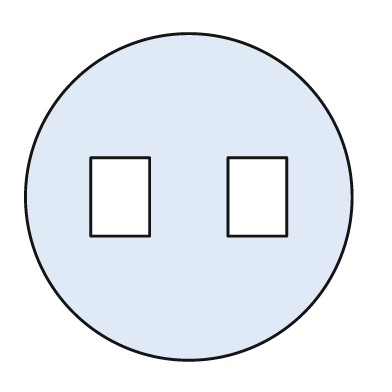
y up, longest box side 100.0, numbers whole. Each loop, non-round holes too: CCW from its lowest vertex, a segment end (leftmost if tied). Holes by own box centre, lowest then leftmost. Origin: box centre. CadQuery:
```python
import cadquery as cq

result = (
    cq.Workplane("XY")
    .moveTo(0.0, 0.0)
    .circle(50.0)
    .moveTo(-30.0, -12.0)
    .lineTo(-12.0, -12.0)
    .lineTo(-12.0, 12.0)
    .lineTo(-30.0, 12.0)
    .close()
    .moveTo(12.0, -12.0)
    .lineTo(30.0, -12.0)
    .lineTo(30.0, 12.0)
    .lineTo(12.0, 12.0)
    .close()
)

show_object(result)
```